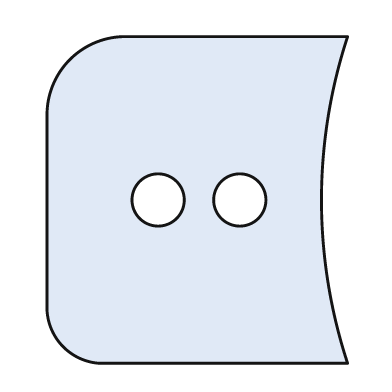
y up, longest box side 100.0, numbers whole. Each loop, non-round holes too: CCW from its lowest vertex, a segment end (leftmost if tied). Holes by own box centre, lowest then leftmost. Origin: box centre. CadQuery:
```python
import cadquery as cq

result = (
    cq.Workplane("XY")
    .moveTo(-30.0, -50.0)
    .lineTo(46.0, -50.0)
    .threePointArc((38.0, 0.0), (46.0, 50.0))
    .lineTo(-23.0, 50.0)
    .threePointArc((-39.0, 43.0), (-46.0, 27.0))
    .lineTo(-46.0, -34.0)
    .threePointArc((-41.0, -45.0), (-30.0, -50.0))
    .close()
    .moveTo(-12.0, 0.0)
    .circle(8.0)
    .moveTo(13.0, 0.0)
    .circle(8.0)
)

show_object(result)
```